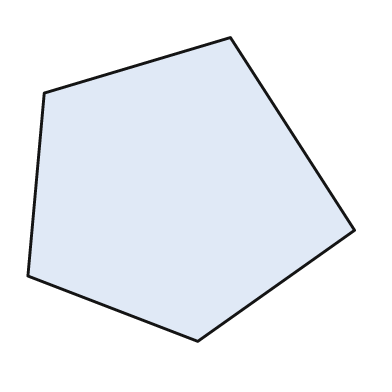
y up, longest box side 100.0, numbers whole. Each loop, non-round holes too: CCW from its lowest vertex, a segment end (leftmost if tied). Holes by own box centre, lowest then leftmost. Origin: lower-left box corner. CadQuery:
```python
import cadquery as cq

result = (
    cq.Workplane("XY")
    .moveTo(52.0, 0.0)
    .lineTo(100.0, 34.0)
    .lineTo(62.0, 93.0)
    .lineTo(5.0, 76.0)
    .lineTo(0.0, 20.0)
    .close()
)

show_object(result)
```